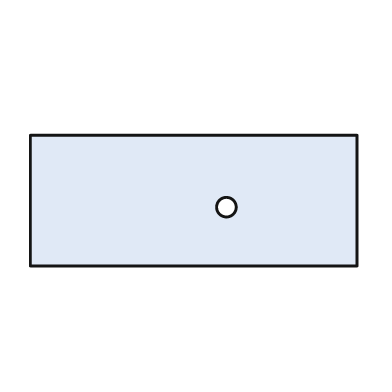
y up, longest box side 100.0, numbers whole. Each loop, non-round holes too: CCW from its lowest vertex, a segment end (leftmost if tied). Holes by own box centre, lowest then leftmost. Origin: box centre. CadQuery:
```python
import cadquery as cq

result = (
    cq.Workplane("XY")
    .moveTo(-50.0, -20.0)
    .lineTo(50.0, -20.0)
    .lineTo(50.0, 20.0)
    .lineTo(-50.0, 20.0)
    .close()
    .moveTo(10.0, -2.0)
    .circle(3.0)
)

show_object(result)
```